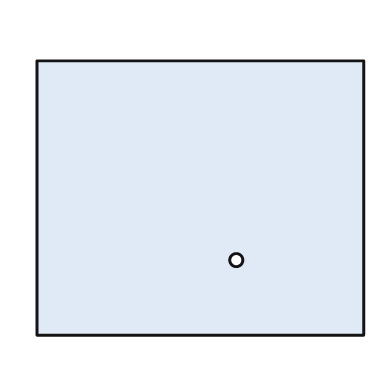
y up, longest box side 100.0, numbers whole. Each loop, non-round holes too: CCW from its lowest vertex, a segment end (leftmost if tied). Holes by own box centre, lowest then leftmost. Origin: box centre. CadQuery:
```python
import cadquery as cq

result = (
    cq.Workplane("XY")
    .moveTo(-50.0, -42.0)
    .lineTo(50.0, -42.0)
    .lineTo(50.0, 42.0)
    .lineTo(-50.0, 42.0)
    .close()
    .moveTo(11.0, -19.0)
    .circle(2.0)
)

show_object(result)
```